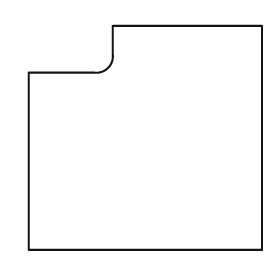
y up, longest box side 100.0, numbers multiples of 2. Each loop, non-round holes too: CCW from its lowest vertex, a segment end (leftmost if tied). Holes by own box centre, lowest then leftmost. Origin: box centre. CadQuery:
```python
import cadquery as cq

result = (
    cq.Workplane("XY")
    .moveTo(-50.0, -48.0)
    .lineTo(50.0, -48.0)
    .lineTo(50.0, 48.0)
    .lineTo(-14.0, 48.0)
    .lineTo(-14.0, 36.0)
    .threePointArc((-16.0, 30.0), (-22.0, 28.0))
    .lineTo(-50.0, 28.0)
    .close()
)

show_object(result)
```